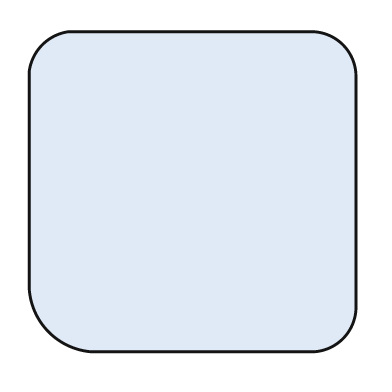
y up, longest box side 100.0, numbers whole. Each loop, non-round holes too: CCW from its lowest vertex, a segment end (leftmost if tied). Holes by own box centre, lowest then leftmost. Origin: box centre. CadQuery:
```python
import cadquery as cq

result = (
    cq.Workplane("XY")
    .moveTo(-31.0, -49.0)
    .lineTo(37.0, -49.0)
    .threePointArc((46.0, -45.0), (50.0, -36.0))
    .lineTo(50.0, 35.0)
    .threePointArc((46.0, 45.0), (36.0, 49.0))
    .lineTo(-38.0, 49.0)
    .threePointArc((-46.0, 45.0), (-50.0, 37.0))
    .lineTo(-50.0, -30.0)
    .threePointArc((-44.0, -43.0), (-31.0, -49.0))
    .close()
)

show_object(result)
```